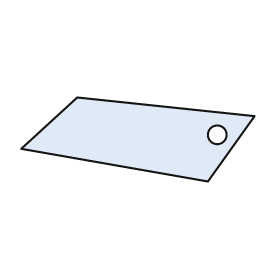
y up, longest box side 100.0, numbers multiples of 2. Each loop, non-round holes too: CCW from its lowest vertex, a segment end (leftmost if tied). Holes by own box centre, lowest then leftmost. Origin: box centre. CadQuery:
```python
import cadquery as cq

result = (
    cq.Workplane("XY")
    .moveTo(30.0, -18.0)
    .lineTo(50.0, 10.0)
    .lineTo(-26.0, 18.0)
    .lineTo(-50.0, -4.0)
    .close()
    .moveTo(34.0, 2.0)
    .circle(4.0)
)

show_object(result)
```